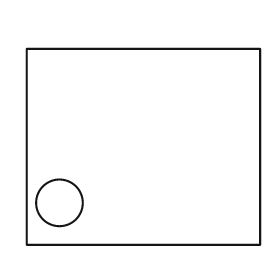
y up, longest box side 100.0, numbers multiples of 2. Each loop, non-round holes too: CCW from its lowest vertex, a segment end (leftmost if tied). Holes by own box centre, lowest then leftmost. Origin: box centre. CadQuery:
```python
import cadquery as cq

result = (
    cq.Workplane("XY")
    .moveTo(-50.0, -42.0)
    .lineTo(50.0, -42.0)
    .lineTo(50.0, 42.0)
    .lineTo(-50.0, 42.0)
    .close()
    .moveTo(-36.0, -24.0)
    .circle(10.0)
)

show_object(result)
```